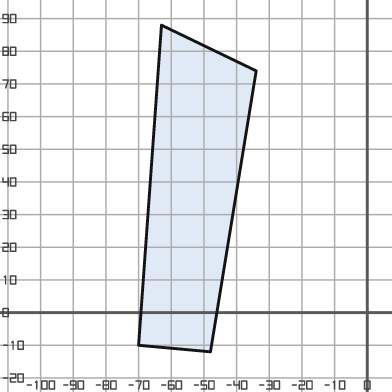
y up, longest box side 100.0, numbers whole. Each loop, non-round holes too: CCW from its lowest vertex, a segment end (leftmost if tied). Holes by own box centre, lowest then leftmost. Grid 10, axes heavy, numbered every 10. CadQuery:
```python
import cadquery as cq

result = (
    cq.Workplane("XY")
    .moveTo(-48.0, -12.0)
    .lineTo(-34.0, 74.0)
    .lineTo(-63.0, 88.0)
    .lineTo(-70.0, -10.0)
    .close()
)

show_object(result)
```